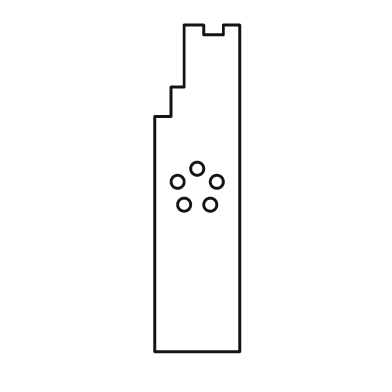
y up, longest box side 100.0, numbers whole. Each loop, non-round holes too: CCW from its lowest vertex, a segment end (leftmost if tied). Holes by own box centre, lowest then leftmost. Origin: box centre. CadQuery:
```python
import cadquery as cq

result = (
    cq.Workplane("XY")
    .moveTo(-13.0, -50.0)
    .lineTo(13.0, -50.0)
    .lineTo(13.0, 50.0)
    .lineTo(8.0, 50.0)
    .lineTo(8.0, 47.0)
    .lineTo(2.0, 47.0)
    .lineTo(2.0, 50.0)
    .lineTo(-4.0, 50.0)
    .lineTo(-4.0, 31.0)
    .lineTo(-8.0, 31.0)
    .lineTo(-8.0, 22.0)
    .lineTo(-13.0, 22.0)
    .close()
    .moveTo(-4.0, -5.0)
    .circle(2.0)
    .moveTo(4.0, -5.0)
    .circle(2.0)
    .moveTo(-6.0, 2.0)
    .circle(2.0)
    .moveTo(6.0, 2.0)
    .circle(2.0)
    .moveTo(0.0, 6.0)
    .circle(2.0)
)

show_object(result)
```